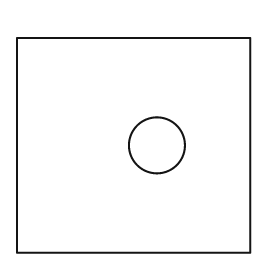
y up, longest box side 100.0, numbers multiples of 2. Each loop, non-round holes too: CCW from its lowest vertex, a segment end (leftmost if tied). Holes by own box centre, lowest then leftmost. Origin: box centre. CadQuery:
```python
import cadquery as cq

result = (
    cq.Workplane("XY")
    .moveTo(-50.0, -46.0)
    .lineTo(50.0, -46.0)
    .lineTo(50.0, 46.0)
    .lineTo(-50.0, 46.0)
    .close()
    .moveTo(10.0, 0.0)
    .circle(12.0)
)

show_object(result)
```